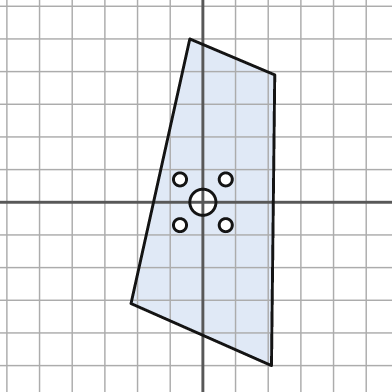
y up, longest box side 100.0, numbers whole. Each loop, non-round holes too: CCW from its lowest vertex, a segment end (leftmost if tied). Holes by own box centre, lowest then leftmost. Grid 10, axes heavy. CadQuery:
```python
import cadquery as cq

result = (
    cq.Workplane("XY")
    .moveTo(21.0, -50.0)
    .lineTo(22.0, 39.0)
    .lineTo(-4.0, 50.0)
    .lineTo(-22.0, -31.0)
    .close()
    .moveTo(-7.0, -7.0)
    .circle(2.0)
    .moveTo(7.0, -7.0)
    .circle(2.0)
    .moveTo(0.0, 0.0)
    .circle(4.0)
    .moveTo(-7.0, 7.0)
    .circle(2.0)
    .moveTo(7.0, 7.0)
    .circle(2.0)
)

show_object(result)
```